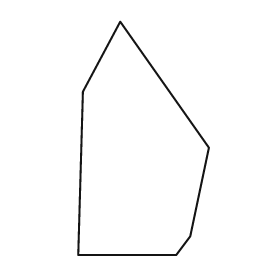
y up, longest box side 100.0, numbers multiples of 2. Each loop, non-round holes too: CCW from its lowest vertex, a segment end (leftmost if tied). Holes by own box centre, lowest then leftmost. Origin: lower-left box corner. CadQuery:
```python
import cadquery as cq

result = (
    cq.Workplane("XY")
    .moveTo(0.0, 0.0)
    .lineTo(42.0, 0.0)
    .lineTo(48.0, 8.0)
    .lineTo(56.0, 46.0)
    .lineTo(18.0, 100.0)
    .lineTo(2.0, 70.0)
    .close()
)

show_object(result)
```